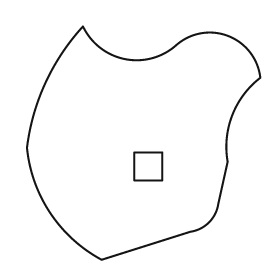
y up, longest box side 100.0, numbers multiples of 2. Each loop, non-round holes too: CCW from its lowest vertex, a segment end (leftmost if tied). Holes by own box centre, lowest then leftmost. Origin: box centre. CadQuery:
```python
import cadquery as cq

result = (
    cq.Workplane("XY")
    .moveTo(-18.0, -50.0)
    .lineTo(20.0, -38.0)
    .threePointArc((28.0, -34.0), (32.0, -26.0))
    .lineTo(36.0, -8.0)
    .threePointArc((38.0, 12.0), (50.0, 28.0))
    .threePointArc((36.0, 46.0), (14.0, 42.0))
    .threePointArc((-8.0, 36.0), (-26.0, 50.0))
    .threePointArc((-42.0, 26.0), (-50.0, -2.0))
    .threePointArc((-40.0, -30.0), (-18.0, -50.0))
    .close()
    .moveTo(-4.0, -16.0)
    .lineTo(8.0, -16.0)
    .lineTo(8.0, -4.0)
    .lineTo(-4.0, -4.0)
    .close()
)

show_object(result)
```